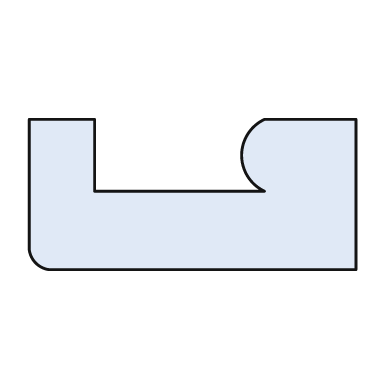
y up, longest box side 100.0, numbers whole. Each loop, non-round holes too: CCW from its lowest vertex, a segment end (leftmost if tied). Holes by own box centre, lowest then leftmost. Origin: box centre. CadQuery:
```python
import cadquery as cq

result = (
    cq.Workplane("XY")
    .moveTo(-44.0, -23.0)
    .lineTo(50.0, -23.0)
    .lineTo(50.0, 23.0)
    .lineTo(22.0, 23.0)
    .threePointArc((15.0, 12.0), (22.0, 1.0))
    .lineTo(-30.0, 1.0)
    .lineTo(-30.0, 23.0)
    .lineTo(-50.0, 23.0)
    .lineTo(-50.0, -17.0)
    .threePointArc((-48.0, -21.0), (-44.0, -23.0))
    .close()
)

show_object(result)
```